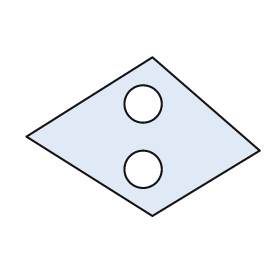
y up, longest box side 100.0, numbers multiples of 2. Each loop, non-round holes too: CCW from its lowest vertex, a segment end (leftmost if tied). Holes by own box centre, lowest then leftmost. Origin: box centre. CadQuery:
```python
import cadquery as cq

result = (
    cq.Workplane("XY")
    .moveTo(4.0, -34.0)
    .lineTo(50.0, -6.0)
    .lineTo(4.0, 34.0)
    .lineTo(-50.0, 0.0)
    .close()
    .moveTo(0.0, -14.0)
    .circle(8.0)
    .moveTo(0.0, 14.0)
    .circle(8.0)
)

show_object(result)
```